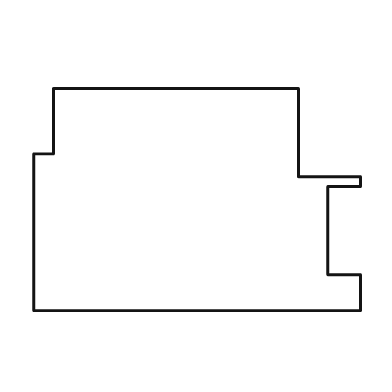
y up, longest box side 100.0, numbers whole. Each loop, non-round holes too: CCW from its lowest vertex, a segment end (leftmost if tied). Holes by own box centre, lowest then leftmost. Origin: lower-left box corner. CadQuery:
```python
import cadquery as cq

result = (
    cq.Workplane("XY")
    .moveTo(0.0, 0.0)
    .lineTo(100.0, 0.0)
    .lineTo(100.0, 11.0)
    .lineTo(90.0, 11.0)
    .lineTo(90.0, 38.0)
    .lineTo(100.0, 38.0)
    .lineTo(100.0, 41.0)
    .lineTo(81.0, 41.0)
    .lineTo(81.0, 68.0)
    .lineTo(6.0, 68.0)
    .lineTo(6.0, 48.0)
    .lineTo(0.0, 48.0)
    .close()
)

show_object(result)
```